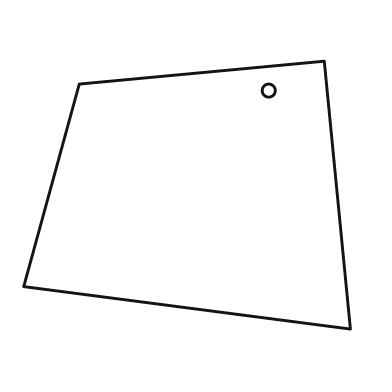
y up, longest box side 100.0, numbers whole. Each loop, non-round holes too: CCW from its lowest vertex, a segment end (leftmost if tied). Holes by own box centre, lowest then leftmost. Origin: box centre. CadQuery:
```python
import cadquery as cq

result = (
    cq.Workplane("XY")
    .moveTo(50.0, -41.0)
    .lineTo(42.0, 41.0)
    .lineTo(-33.0, 34.0)
    .lineTo(-50.0, -28.0)
    .close()
    .moveTo(25.0, 32.0)
    .circle(2.0)
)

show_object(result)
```